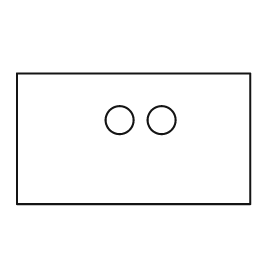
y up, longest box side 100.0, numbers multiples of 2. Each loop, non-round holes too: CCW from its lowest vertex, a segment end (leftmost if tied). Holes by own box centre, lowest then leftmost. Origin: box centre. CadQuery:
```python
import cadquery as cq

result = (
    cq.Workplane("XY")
    .moveTo(-50.0, -28.0)
    .lineTo(50.0, -28.0)
    .lineTo(50.0, 28.0)
    .lineTo(-50.0, 28.0)
    .close()
    .moveTo(-6.0, 8.0)
    .circle(6.0)
    .moveTo(12.0, 8.0)
    .circle(6.0)
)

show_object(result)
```